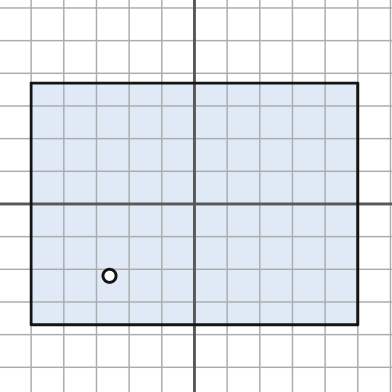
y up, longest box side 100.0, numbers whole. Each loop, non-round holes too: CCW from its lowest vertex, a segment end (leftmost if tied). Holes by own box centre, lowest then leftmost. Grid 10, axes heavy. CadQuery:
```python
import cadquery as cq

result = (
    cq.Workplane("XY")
    .moveTo(-50.0, -37.0)
    .lineTo(50.0, -37.0)
    .lineTo(50.0, 37.0)
    .lineTo(-50.0, 37.0)
    .close()
    .moveTo(-26.0, -22.0)
    .circle(2.0)
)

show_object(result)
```